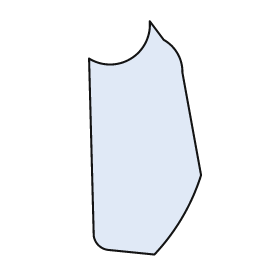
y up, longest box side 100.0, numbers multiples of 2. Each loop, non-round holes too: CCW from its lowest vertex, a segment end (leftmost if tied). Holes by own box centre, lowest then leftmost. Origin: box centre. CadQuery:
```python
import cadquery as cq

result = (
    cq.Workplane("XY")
    .moveTo(4.0, -50.0)
    .threePointArc((16.0, -34.0), (24.0, -16.0))
    .lineTo(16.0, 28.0)
    .threePointArc((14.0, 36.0), (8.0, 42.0))
    .lineTo(2.0, 50.0)
    .threePointArc((-6.0, 34.0), (-24.0, 34.0))
    .lineTo(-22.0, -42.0)
    .threePointArc((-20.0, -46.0), (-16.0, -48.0))
    .close()
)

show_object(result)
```